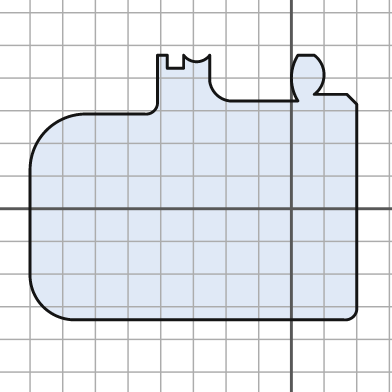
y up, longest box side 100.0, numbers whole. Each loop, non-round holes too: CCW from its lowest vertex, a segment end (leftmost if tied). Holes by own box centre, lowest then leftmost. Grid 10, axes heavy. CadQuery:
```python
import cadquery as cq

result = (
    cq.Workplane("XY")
    .moveTo(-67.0, -34.0)
    .lineTo(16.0, -34.0)
    .threePointArc((19.0, -33.0), (20.0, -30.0))
    .lineTo(20.0, 32.0)
    .lineTo(17.0, 35.0)
    .lineTo(7.0, 35.0)
    .threePointArc((10.0, 41.0), (7.0, 47.0))
    .lineTo(2.0, 47.0)
    .threePointArc((0.0, 40.0), (2.0, 33.0))
    .lineTo(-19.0, 33.0)
    .threePointArc((-23.0, 35.0), (-25.0, 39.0))
    .lineTo(-25.0, 47.0)
    .threePointArc((-29.0, 45.0), (-33.0, 47.0))
    .lineTo(-33.0, 43.0)
    .lineTo(-38.0, 43.0)
    .lineTo(-38.0, 47.0)
    .lineTo(-41.0, 47.0)
    .lineTo(-41.0, 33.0)
    .threePointArc((-42.0, 30.0), (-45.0, 29.0))
    .lineTo(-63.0, 29.0)
    .threePointArc((-75.0, 24.0), (-80.0, 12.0))
    .lineTo(-80.0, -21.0)
    .threePointArc((-76.0, -30.0), (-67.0, -34.0))
    .close()
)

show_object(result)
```